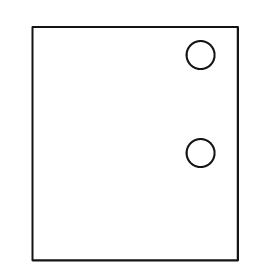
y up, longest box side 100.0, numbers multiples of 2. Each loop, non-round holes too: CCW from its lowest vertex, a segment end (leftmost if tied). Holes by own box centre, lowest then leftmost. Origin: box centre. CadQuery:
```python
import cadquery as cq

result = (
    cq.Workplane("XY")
    .moveTo(-44.0, -50.0)
    .lineTo(44.0, -50.0)
    .lineTo(44.0, 50.0)
    .lineTo(-44.0, 50.0)
    .close()
    .moveTo(28.0, -4.0)
    .circle(6.0)
    .moveTo(28.0, 38.0)
    .circle(6.0)
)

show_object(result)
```